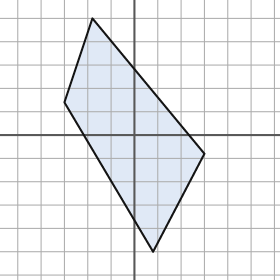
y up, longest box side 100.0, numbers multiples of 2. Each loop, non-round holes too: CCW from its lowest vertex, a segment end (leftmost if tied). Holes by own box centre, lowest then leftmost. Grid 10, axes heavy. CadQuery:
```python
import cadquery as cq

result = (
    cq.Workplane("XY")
    .moveTo(8.0, -50.0)
    .lineTo(30.0, -8.0)
    .lineTo(-18.0, 50.0)
    .lineTo(-30.0, 14.0)
    .close()
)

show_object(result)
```